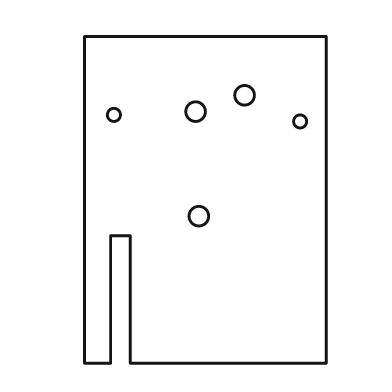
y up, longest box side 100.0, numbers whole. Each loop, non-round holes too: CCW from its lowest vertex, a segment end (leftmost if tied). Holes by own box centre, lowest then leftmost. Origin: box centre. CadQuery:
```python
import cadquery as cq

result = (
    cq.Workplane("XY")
    .moveTo(-37.0, -50.0)
    .lineTo(-29.0, -50.0)
    .lineTo(-29.0, -11.0)
    .lineTo(-23.0, -11.0)
    .lineTo(-23.0, -50.0)
    .lineTo(37.0, -50.0)
    .lineTo(37.0, 50.0)
    .lineTo(-37.0, 50.0)
    .close()
    .moveTo(-2.0, -5.0)
    .circle(3.0)
    .moveTo(29.0, 24.0)
    .circle(2.0)
    .moveTo(-28.0, 26.0)
    .circle(2.0)
    .moveTo(-3.0, 27.0)
    .circle(3.0)
    .moveTo(12.0, 32.0)
    .circle(3.0)
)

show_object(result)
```